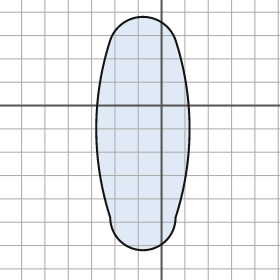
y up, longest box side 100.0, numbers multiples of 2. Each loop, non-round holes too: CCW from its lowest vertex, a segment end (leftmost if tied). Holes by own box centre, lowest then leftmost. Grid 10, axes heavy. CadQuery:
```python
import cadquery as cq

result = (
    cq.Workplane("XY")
    .moveTo(-22.0, -48.0)
    .threePointArc((-8.0, -62.0), (6.0, -48.0))
    .threePointArc((12.0, -10.0), (6.0, 28.0))
    .threePointArc((-8.0, 38.0), (-22.0, 28.0))
    .threePointArc((-28.0, -10.0), (-22.0, -48.0))
    .close()
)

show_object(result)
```